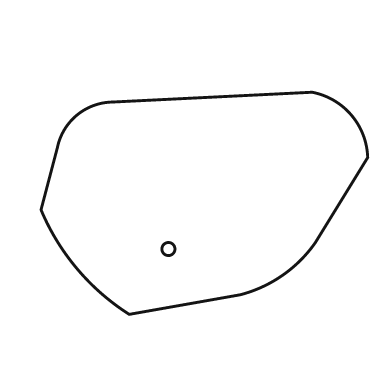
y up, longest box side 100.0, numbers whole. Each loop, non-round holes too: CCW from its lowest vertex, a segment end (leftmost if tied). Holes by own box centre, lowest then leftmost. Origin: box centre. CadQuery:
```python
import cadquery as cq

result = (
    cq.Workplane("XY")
    .moveTo(-23.0, -34.0)
    .lineTo(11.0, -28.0)
    .threePointArc((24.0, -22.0), (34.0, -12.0))
    .lineTo(50.0, 14.0)
    .threePointArc((45.0, 27.0), (33.0, 34.0))
    .lineTo(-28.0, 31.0)
    .threePointArc((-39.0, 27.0), (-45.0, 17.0))
    .lineTo(-50.0, -2.0)
    .threePointArc((-39.0, -20.0), (-23.0, -34.0))
    .close()
    .moveTo(-11.0, -14.0)
    .circle(2.0)
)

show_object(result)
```